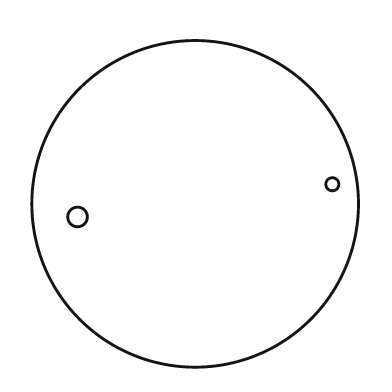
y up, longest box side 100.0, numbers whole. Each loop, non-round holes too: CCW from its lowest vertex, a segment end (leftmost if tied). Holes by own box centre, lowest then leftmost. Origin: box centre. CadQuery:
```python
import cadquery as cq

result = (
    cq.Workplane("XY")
    .moveTo(0.0, 0.0)
    .circle(50.0)
    .moveTo(-36.0, -4.0)
    .circle(3.0)
    .moveTo(42.0, 6.0)
    .circle(2.0)
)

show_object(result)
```